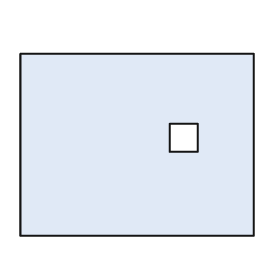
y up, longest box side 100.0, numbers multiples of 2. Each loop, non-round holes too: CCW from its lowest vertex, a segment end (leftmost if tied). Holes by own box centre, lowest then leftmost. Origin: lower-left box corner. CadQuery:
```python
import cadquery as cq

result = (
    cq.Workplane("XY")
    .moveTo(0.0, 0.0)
    .lineTo(100.0, 0.0)
    .lineTo(100.0, 78.0)
    .lineTo(0.0, 78.0)
    .close()
    .moveTo(64.0, 36.0)
    .lineTo(76.0, 36.0)
    .lineTo(76.0, 48.0)
    .lineTo(64.0, 48.0)
    .close()
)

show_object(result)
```